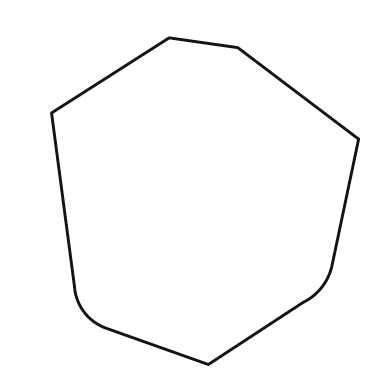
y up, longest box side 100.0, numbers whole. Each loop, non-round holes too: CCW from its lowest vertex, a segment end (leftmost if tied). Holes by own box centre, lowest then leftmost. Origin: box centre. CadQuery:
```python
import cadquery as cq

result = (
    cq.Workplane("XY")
    .moveTo(1.0, -50.0)
    .lineTo(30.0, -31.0)
    .threePointArc((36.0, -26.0), (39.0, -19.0))
    .lineTo(47.0, 19.0)
    .lineTo(10.0, 47.0)
    .lineTo(-11.0, 50.0)
    .lineTo(-47.0, 27.0)
    .lineTo(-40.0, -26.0)
    .threePointArc((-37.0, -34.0), (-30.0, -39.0))
    .close()
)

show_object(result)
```